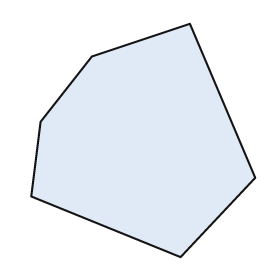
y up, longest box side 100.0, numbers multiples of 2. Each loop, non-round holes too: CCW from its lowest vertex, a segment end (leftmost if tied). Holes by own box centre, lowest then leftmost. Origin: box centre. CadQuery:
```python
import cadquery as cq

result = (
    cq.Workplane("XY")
    .moveTo(16.0, -50.0)
    .lineTo(48.0, -16.0)
    .lineTo(20.0, 50.0)
    .lineTo(-22.0, 36.0)
    .lineTo(-44.0, 8.0)
    .lineTo(-48.0, -24.0)
    .close()
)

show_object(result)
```